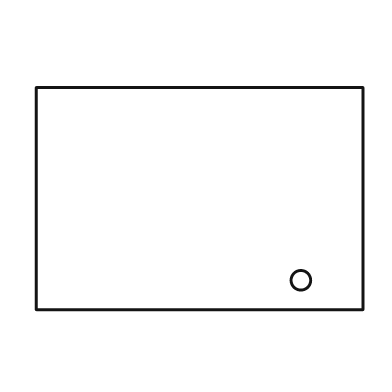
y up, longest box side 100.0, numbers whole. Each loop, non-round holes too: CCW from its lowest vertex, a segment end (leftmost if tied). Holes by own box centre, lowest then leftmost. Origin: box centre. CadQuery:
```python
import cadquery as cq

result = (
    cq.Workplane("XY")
    .moveTo(-50.0, -34.0)
    .lineTo(50.0, -34.0)
    .lineTo(50.0, 34.0)
    .lineTo(-50.0, 34.0)
    .close()
    .moveTo(31.0, -25.0)
    .circle(3.0)
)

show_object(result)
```